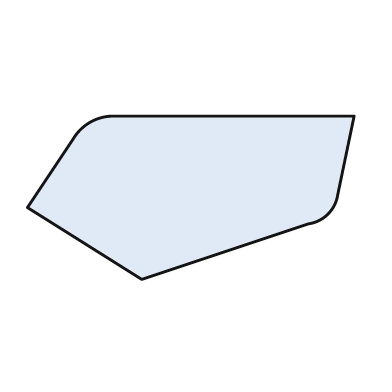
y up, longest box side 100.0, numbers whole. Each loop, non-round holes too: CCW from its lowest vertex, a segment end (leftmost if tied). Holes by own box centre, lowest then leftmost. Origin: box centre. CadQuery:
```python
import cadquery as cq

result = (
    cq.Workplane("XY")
    .moveTo(-15.0, -25.0)
    .lineTo(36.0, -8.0)
    .threePointArc((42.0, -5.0), (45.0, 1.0))
    .lineTo(50.0, 25.0)
    .lineTo(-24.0, 25.0)
    .threePointArc((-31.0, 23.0), (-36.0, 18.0))
    .lineTo(-50.0, -3.0)
    .close()
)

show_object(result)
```